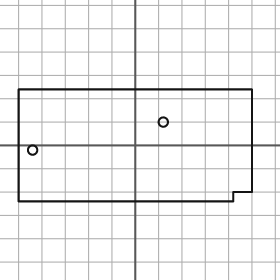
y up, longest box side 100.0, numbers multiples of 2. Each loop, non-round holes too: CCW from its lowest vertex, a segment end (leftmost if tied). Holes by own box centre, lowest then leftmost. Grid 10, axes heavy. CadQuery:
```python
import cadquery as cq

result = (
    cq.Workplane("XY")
    .moveTo(-50.0, -24.0)
    .lineTo(42.0, -24.0)
    .lineTo(42.0, -20.0)
    .lineTo(50.0, -20.0)
    .lineTo(50.0, 24.0)
    .lineTo(-50.0, 24.0)
    .close()
    .moveTo(-44.0, -2.0)
    .circle(2.0)
    .moveTo(12.0, 10.0)
    .circle(2.0)
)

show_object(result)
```